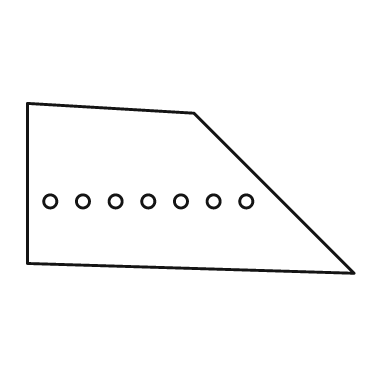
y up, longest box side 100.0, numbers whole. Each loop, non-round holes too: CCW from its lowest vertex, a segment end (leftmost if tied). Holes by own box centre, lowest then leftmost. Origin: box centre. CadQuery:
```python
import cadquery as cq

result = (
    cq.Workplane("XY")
    .moveTo(50.0, -26.0)
    .lineTo(1.0, 23.0)
    .lineTo(-50.0, 26.0)
    .lineTo(-50.0, -23.0)
    .close()
    .moveTo(-43.0, -4.0)
    .circle(2.0)
    .moveTo(-33.0, -4.0)
    .circle(2.0)
    .moveTo(-23.0, -4.0)
    .circle(2.0)
    .moveTo(-13.0, -4.0)
    .circle(2.0)
    .moveTo(-3.0, -4.0)
    .circle(2.0)
    .moveTo(7.0, -4.0)
    .circle(2.0)
    .moveTo(17.0, -4.0)
    .circle(2.0)
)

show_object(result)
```